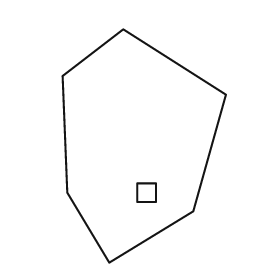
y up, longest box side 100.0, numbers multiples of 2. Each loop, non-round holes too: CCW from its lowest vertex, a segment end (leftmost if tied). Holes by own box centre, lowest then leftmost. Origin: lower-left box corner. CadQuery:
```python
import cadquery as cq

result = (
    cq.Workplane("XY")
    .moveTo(20.0, 0.0)
    .lineTo(56.0, 22.0)
    .lineTo(70.0, 72.0)
    .lineTo(26.0, 100.0)
    .lineTo(0.0, 80.0)
    .lineTo(2.0, 30.0)
    .close()
    .moveTo(32.0, 26.0)
    .lineTo(40.0, 26.0)
    .lineTo(40.0, 34.0)
    .lineTo(32.0, 34.0)
    .close()
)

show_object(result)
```